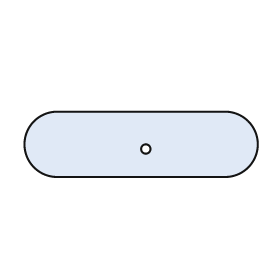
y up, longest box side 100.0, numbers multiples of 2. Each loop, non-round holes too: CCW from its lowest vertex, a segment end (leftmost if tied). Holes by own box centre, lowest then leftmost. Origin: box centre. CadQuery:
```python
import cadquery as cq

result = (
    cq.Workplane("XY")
    .moveTo(-36.0, -14.0)
    .lineTo(36.0, -14.0)
    .threePointArc((50.0, 0.0), (36.0, 14.0))
    .lineTo(-36.0, 14.0)
    .threePointArc((-50.0, 0.0), (-36.0, -14.0))
    .close()
    .moveTo(2.0, -2.0)
    .circle(2.0)
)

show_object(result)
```